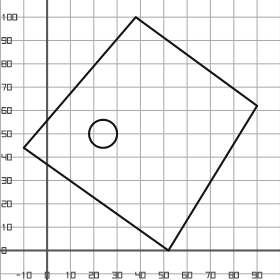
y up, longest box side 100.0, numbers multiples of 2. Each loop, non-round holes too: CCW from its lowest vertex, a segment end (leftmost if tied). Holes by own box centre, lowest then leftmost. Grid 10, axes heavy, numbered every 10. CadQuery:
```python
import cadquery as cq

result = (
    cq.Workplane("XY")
    .moveTo(52.0, 0.0)
    .lineTo(90.0, 62.0)
    .lineTo(38.0, 100.0)
    .lineTo(-10.0, 44.0)
    .close()
    .moveTo(24.0, 50.0)
    .circle(6.0)
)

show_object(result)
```